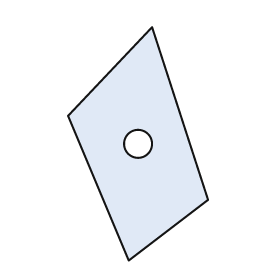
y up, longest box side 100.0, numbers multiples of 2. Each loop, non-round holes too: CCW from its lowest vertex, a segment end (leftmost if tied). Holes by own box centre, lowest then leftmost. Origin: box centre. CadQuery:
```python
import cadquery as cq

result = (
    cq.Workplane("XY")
    .moveTo(-4.0, -50.0)
    .lineTo(30.0, -24.0)
    .lineTo(6.0, 50.0)
    .lineTo(-30.0, 12.0)
    .close()
    .moveTo(0.0, 0.0)
    .circle(6.0)
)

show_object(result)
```